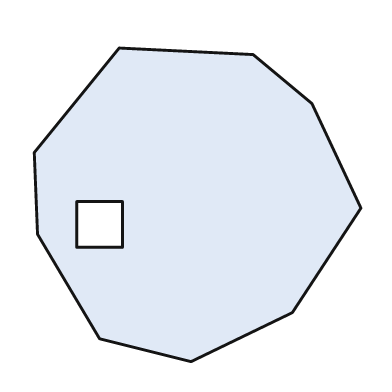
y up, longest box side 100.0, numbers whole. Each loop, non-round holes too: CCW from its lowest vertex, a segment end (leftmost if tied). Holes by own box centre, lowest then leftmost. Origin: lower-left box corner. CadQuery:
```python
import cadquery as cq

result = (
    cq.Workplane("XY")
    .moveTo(48.0, 0.0)
    .lineTo(79.0, 15.0)
    .lineTo(100.0, 47.0)
    .lineTo(85.0, 79.0)
    .lineTo(67.0, 94.0)
    .lineTo(26.0, 96.0)
    .lineTo(0.0, 64.0)
    .lineTo(1.0, 39.0)
    .lineTo(20.0, 7.0)
    .close()
    .moveTo(13.0, 35.0)
    .lineTo(27.0, 35.0)
    .lineTo(27.0, 49.0)
    .lineTo(13.0, 49.0)
    .close()
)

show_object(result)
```